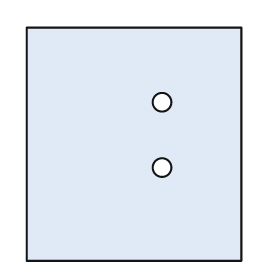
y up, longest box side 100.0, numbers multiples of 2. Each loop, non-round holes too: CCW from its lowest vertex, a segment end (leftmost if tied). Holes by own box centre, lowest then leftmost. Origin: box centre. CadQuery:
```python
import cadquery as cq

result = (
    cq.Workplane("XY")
    .moveTo(-46.0, -50.0)
    .lineTo(46.0, -50.0)
    .lineTo(46.0, 50.0)
    .lineTo(-46.0, 50.0)
    .close()
    .moveTo(12.0, -10.0)
    .circle(4.0)
    .moveTo(12.0, 18.0)
    .circle(4.0)
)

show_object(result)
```